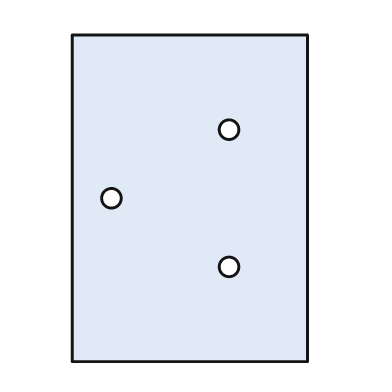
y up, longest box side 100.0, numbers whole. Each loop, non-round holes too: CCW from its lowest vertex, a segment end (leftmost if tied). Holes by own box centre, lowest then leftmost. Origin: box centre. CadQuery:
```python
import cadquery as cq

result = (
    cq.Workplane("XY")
    .moveTo(-36.0, -50.0)
    .lineTo(36.0, -50.0)
    .lineTo(36.0, 50.0)
    .lineTo(-36.0, 50.0)
    .close()
    .moveTo(12.0, -21.0)
    .circle(3.0)
    .moveTo(-24.0, 0.0)
    .circle(3.0)
    .moveTo(12.0, 21.0)
    .circle(3.0)
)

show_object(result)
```